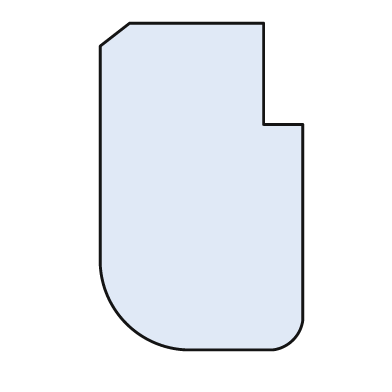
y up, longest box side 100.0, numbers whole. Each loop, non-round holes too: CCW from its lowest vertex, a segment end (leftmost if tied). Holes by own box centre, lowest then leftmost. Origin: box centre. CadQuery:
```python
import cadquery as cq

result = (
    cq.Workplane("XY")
    .moveTo(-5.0, -50.0)
    .lineTo(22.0, -50.0)
    .threePointArc((28.0, -47.0), (31.0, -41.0))
    .lineTo(31.0, 19.0)
    .lineTo(19.0, 19.0)
    .lineTo(19.0, 50.0)
    .lineTo(-22.0, 50.0)
    .lineTo(-31.0, 43.0)
    .lineTo(-31.0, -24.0)
    .threePointArc((-23.0, -42.0), (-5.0, -50.0))
    .close()
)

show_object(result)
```